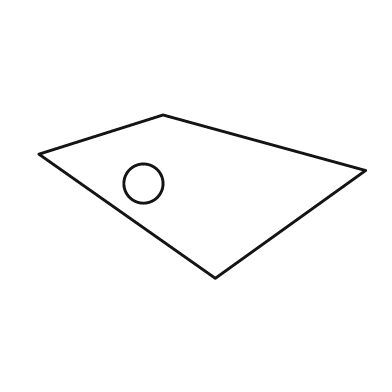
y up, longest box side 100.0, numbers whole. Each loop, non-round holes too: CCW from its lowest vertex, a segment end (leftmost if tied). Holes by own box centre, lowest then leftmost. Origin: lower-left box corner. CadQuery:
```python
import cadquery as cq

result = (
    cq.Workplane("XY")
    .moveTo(54.0, 0.0)
    .lineTo(100.0, 33.0)
    .lineTo(38.0, 50.0)
    .lineTo(0.0, 38.0)
    .close()
    .moveTo(32.0, 29.0)
    .circle(6.0)
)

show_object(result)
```